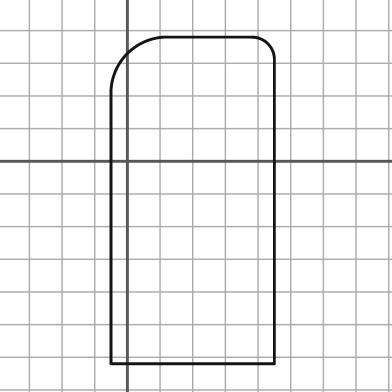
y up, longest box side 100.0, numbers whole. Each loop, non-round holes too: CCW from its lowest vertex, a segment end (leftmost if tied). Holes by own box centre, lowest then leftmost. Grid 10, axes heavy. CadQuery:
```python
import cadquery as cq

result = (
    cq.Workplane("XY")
    .moveTo(-5.0, -62.0)
    .lineTo(45.0, -62.0)
    .lineTo(45.0, 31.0)
    .threePointArc((43.0, 36.0), (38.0, 38.0))
    .lineTo(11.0, 38.0)
    .threePointArc((0.0, 33.0), (-5.0, 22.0))
    .close()
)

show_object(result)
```